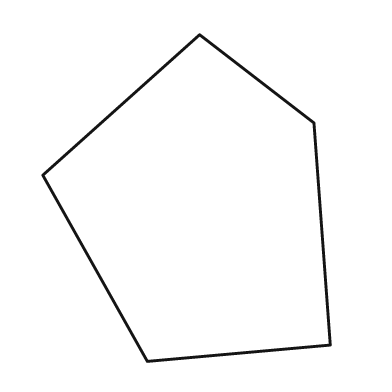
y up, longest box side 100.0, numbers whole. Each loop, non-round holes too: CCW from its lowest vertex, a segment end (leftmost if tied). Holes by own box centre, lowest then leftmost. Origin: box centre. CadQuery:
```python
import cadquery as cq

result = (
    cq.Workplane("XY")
    .moveTo(-12.0, -50.0)
    .lineTo(44.0, -45.0)
    .lineTo(39.0, 23.0)
    .lineTo(4.0, 50.0)
    .lineTo(-44.0, 7.0)
    .close()
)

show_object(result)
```